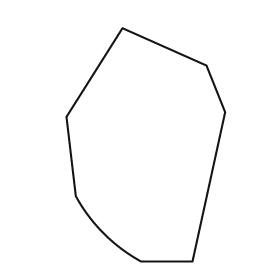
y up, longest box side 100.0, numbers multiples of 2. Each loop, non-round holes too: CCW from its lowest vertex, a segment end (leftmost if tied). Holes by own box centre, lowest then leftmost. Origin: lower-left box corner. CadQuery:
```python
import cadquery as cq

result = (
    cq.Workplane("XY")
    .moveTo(32.0, 0.0)
    .lineTo(54.0, 0.0)
    .lineTo(68.0, 64.0)
    .lineTo(60.0, 84.0)
    .lineTo(24.0, 100.0)
    .lineTo(0.0, 62.0)
    .lineTo(4.0, 28.0)
    .threePointArc((16.0, 12.0), (32.0, 0.0))
    .close()
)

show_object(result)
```